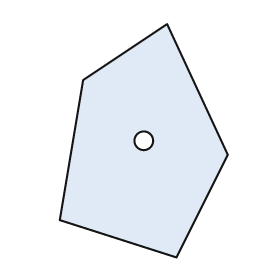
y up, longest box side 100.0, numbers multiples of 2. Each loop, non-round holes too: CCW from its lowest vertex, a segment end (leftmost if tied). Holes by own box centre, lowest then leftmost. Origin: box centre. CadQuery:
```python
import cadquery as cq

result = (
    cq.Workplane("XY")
    .moveTo(14.0, -50.0)
    .lineTo(36.0, -6.0)
    .lineTo(10.0, 50.0)
    .lineTo(-26.0, 26.0)
    .lineTo(-36.0, -34.0)
    .close()
    .moveTo(0.0, 0.0)
    .circle(4.0)
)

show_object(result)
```